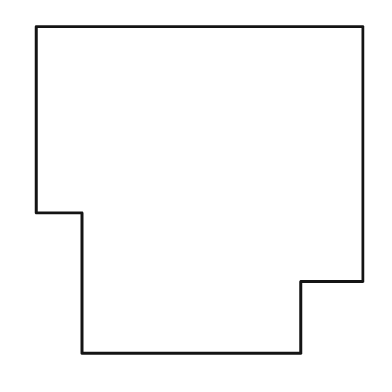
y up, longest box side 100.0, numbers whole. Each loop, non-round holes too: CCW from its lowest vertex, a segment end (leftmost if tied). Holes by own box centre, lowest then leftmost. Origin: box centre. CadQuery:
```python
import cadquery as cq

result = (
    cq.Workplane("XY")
    .moveTo(-36.0, -50.0)
    .lineTo(31.0, -50.0)
    .lineTo(31.0, -28.0)
    .lineTo(50.0, -28.0)
    .lineTo(50.0, 50.0)
    .lineTo(-50.0, 50.0)
    .lineTo(-50.0, -7.0)
    .lineTo(-36.0, -7.0)
    .close()
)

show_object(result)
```